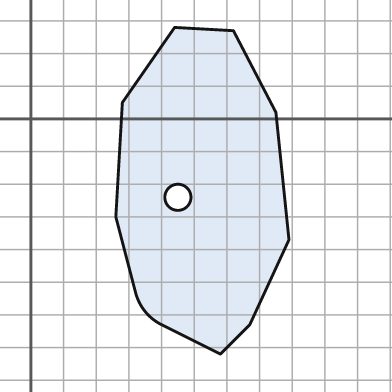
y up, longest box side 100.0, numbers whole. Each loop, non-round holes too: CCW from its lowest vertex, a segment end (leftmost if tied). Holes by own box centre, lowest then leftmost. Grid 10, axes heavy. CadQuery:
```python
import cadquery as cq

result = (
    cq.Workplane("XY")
    .moveTo(58.0, -72.0)
    .lineTo(67.0, -63.0)
    .lineTo(79.0, -37.0)
    .lineTo(75.0, 2.0)
    .lineTo(62.0, 27.0)
    .lineTo(44.0, 28.0)
    .lineTo(28.0, 5.0)
    .lineTo(26.0, -30.0)
    .lineTo(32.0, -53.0)
    .threePointArc((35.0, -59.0), (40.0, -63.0))
    .close()
    .moveTo(45.0, -24.0)
    .circle(4.0)
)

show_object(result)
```